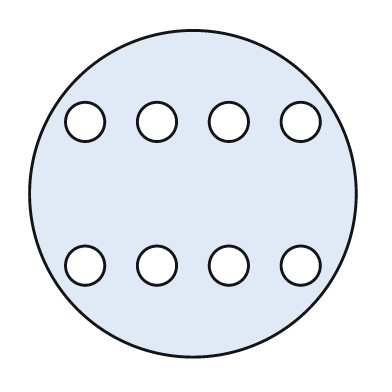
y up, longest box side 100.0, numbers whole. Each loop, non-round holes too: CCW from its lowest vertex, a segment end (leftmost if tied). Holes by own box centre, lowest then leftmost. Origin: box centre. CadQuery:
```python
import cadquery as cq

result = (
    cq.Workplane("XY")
    .moveTo(0.0, 0.0)
    .circle(50.0)
    .moveTo(-33.0, -22.0)
    .circle(6.0)
    .moveTo(-11.0, -22.0)
    .circle(6.0)
    .moveTo(11.0, -22.0)
    .circle(6.0)
    .moveTo(33.0, -22.0)
    .circle(6.0)
    .moveTo(-33.0, 22.0)
    .circle(6.0)
    .moveTo(-11.0, 22.0)
    .circle(6.0)
    .moveTo(11.0, 22.0)
    .circle(6.0)
    .moveTo(33.0, 22.0)
    .circle(6.0)
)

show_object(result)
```